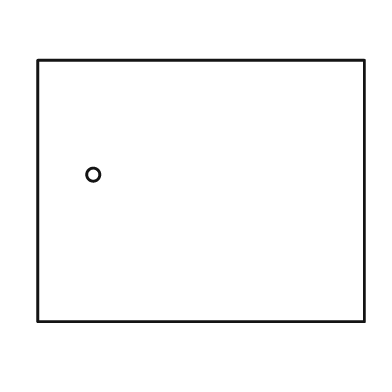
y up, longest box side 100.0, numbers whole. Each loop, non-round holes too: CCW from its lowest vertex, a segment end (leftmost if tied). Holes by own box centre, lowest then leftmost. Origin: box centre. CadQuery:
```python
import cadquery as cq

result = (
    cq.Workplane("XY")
    .moveTo(-50.0, -40.0)
    .lineTo(50.0, -40.0)
    .lineTo(50.0, 40.0)
    .lineTo(-50.0, 40.0)
    .close()
    .moveTo(-33.0, 5.0)
    .circle(2.0)
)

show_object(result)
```